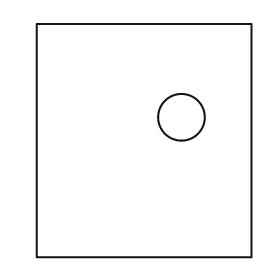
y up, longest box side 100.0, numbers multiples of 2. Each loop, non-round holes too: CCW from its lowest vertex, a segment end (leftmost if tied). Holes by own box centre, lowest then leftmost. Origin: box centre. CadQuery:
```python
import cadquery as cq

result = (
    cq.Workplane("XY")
    .moveTo(-46.0, -50.0)
    .lineTo(46.0, -50.0)
    .lineTo(46.0, 50.0)
    .lineTo(-46.0, 50.0)
    .close()
    .moveTo(16.0, 10.0)
    .circle(10.0)
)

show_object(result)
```